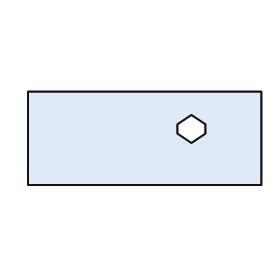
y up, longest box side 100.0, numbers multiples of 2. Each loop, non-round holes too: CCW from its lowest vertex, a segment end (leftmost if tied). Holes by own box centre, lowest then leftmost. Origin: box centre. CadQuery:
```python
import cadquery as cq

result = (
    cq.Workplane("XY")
    .moveTo(-50.0, -20.0)
    .lineTo(50.0, -20.0)
    .lineTo(50.0, 20.0)
    .lineTo(-50.0, 20.0)
    .close()
    .moveTo(20.0, -2.0)
    .lineTo(26.0, 2.0)
    .lineTo(26.0, 6.0)
    .lineTo(20.0, 10.0)
    .lineTo(14.0, 6.0)
    .lineTo(14.0, 2.0)
    .close()
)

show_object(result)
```